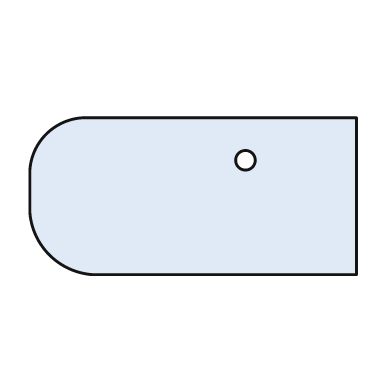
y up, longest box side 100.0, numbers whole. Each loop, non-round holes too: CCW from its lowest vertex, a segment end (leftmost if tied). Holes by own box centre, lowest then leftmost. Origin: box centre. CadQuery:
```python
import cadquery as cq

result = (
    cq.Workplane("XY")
    .moveTo(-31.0, -24.0)
    .lineTo(50.0, -24.0)
    .lineTo(50.0, 24.0)
    .lineTo(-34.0, 24.0)
    .threePointArc((-45.0, 19.0), (-50.0, 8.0))
    .lineTo(-50.0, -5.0)
    .threePointArc((-44.0, -18.0), (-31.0, -24.0))
    .close()
    .moveTo(16.0, 11.0)
    .circle(3.0)
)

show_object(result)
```